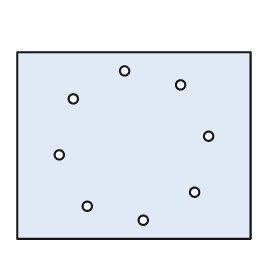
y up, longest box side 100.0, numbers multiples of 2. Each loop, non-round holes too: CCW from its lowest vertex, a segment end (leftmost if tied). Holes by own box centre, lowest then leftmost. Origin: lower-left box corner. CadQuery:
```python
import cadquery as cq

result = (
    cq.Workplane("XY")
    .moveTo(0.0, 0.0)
    .lineTo(100.0, 0.0)
    .lineTo(100.0, 80.0)
    .lineTo(0.0, 80.0)
    .close()
    .moveTo(54.0, 8.0)
    .circle(2.0)
    .moveTo(30.0, 14.0)
    .circle(2.0)
    .moveTo(76.0, 20.0)
    .circle(2.0)
    .moveTo(18.0, 36.0)
    .circle(2.0)
    .moveTo(82.0, 44.0)
    .circle(2.0)
    .moveTo(24.0, 60.0)
    .circle(2.0)
    .moveTo(70.0, 66.0)
    .circle(2.0)
    .moveTo(46.0, 72.0)
    .circle(2.0)
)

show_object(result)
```